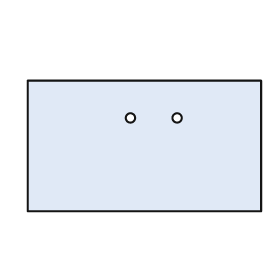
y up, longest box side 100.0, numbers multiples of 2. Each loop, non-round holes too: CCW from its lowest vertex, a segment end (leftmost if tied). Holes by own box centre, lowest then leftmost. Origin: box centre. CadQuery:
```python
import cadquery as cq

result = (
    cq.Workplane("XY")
    .moveTo(-50.0, -28.0)
    .lineTo(50.0, -28.0)
    .lineTo(50.0, 28.0)
    .lineTo(-50.0, 28.0)
    .close()
    .moveTo(-6.0, 12.0)
    .circle(2.0)
    .moveTo(14.0, 12.0)
    .circle(2.0)
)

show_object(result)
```